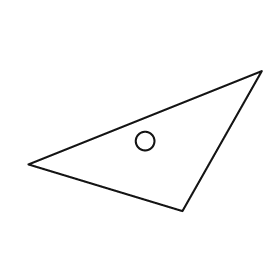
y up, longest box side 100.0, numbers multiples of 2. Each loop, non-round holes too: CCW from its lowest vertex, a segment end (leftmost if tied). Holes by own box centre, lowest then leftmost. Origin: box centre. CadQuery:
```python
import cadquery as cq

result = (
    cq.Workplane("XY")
    .moveTo(16.0, -30.0)
    .lineTo(50.0, 30.0)
    .lineTo(-50.0, -10.0)
    .close()
    .moveTo(0.0, 0.0)
    .circle(4.0)
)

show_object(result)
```